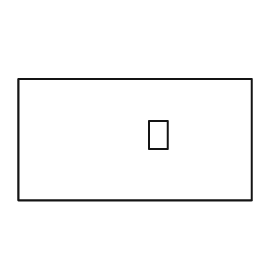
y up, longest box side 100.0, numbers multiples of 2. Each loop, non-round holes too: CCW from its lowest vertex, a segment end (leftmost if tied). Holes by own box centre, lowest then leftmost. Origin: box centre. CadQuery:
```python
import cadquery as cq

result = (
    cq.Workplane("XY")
    .moveTo(-50.0, -26.0)
    .lineTo(50.0, -26.0)
    .lineTo(50.0, 26.0)
    .lineTo(-50.0, 26.0)
    .close()
    .moveTo(6.0, -4.0)
    .lineTo(14.0, -4.0)
    .lineTo(14.0, 8.0)
    .lineTo(6.0, 8.0)
    .close()
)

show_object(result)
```